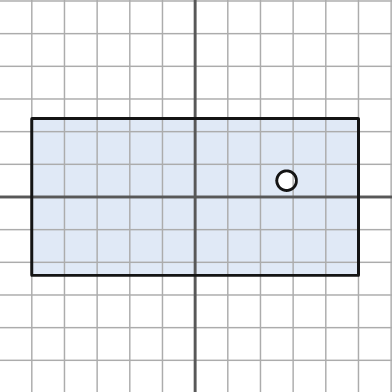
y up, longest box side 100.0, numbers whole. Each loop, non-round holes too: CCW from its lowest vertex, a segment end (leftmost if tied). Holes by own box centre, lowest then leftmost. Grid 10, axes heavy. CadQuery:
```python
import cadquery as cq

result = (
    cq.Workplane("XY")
    .moveTo(-50.0, -24.0)
    .lineTo(50.0, -24.0)
    .lineTo(50.0, 24.0)
    .lineTo(-50.0, 24.0)
    .close()
    .moveTo(28.0, 5.0)
    .circle(3.0)
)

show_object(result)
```